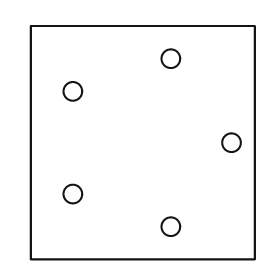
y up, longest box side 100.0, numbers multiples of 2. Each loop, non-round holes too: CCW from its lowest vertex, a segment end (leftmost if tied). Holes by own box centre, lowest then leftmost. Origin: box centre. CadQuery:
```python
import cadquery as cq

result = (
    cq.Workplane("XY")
    .moveTo(-48.0, -50.0)
    .lineTo(48.0, -50.0)
    .lineTo(48.0, 50.0)
    .lineTo(-48.0, 50.0)
    .close()
    .moveTo(12.0, -36.0)
    .circle(4.0)
    .moveTo(-30.0, -22.0)
    .circle(4.0)
    .moveTo(38.0, 0.0)
    .circle(4.0)
    .moveTo(-30.0, 22.0)
    .circle(4.0)
    .moveTo(12.0, 36.0)
    .circle(4.0)
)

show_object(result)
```